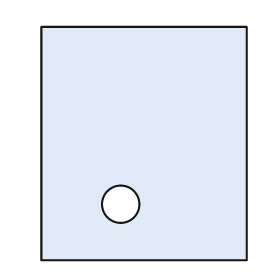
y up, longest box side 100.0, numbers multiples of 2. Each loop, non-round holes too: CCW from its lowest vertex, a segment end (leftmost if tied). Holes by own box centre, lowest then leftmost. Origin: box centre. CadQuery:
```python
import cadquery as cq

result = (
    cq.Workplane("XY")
    .moveTo(-44.0, -50.0)
    .lineTo(44.0, -50.0)
    .lineTo(44.0, 50.0)
    .lineTo(-44.0, 50.0)
    .close()
    .moveTo(-10.0, -26.0)
    .circle(8.0)
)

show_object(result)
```